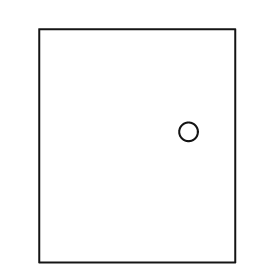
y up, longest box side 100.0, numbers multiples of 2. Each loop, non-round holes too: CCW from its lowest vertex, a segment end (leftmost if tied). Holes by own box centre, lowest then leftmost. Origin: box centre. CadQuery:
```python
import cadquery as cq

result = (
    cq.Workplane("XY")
    .moveTo(-42.0, -50.0)
    .lineTo(42.0, -50.0)
    .lineTo(42.0, 50.0)
    .lineTo(-42.0, 50.0)
    .close()
    .moveTo(22.0, 6.0)
    .circle(4.0)
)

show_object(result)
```